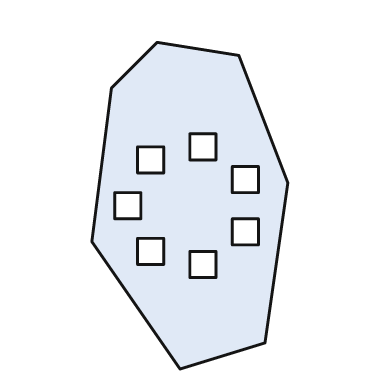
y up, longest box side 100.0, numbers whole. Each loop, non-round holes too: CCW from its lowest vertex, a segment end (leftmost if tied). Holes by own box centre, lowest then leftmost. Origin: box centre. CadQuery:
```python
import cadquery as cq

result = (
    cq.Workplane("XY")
    .moveTo(-3.0, -50.0)
    .lineTo(23.0, -42.0)
    .lineTo(30.0, 7.0)
    .lineTo(15.0, 46.0)
    .lineTo(-10.0, 50.0)
    .lineTo(-24.0, 36.0)
    .lineTo(-30.0, -11.0)
    .close()
    .moveTo(0.0, -22.0)
    .lineTo(8.0, -22.0)
    .lineTo(8.0, -14.0)
    .lineTo(0.0, -14.0)
    .close()
    .moveTo(-16.0, -18.0)
    .lineTo(-8.0, -18.0)
    .lineTo(-8.0, -10.0)
    .lineTo(-16.0, -10.0)
    .close()
    .moveTo(13.0, -12.0)
    .lineTo(21.0, -12.0)
    .lineTo(21.0, -4.0)
    .lineTo(13.0, -4.0)
    .close()
    .moveTo(-23.0, -4.0)
    .lineTo(-15.0, -4.0)
    .lineTo(-15.0, 4.0)
    .lineTo(-23.0, 4.0)
    .close()
    .moveTo(13.0, 4.0)
    .lineTo(21.0, 4.0)
    .lineTo(21.0, 12.0)
    .lineTo(13.0, 12.0)
    .close()
    .moveTo(-16.0, 10.0)
    .lineTo(-8.0, 10.0)
    .lineTo(-8.0, 18.0)
    .lineTo(-16.0, 18.0)
    .close()
    .moveTo(0.0, 14.0)
    .lineTo(8.0, 14.0)
    .lineTo(8.0, 22.0)
    .lineTo(0.0, 22.0)
    .close()
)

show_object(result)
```